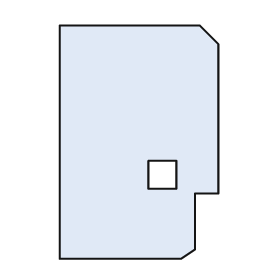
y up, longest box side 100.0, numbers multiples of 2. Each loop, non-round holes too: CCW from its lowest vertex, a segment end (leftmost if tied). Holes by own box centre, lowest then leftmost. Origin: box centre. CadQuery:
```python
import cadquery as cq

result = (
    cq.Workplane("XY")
    .moveTo(-34.0, -50.0)
    .lineTo(18.0, -50.0)
    .lineTo(24.0, -46.0)
    .lineTo(24.0, -22.0)
    .lineTo(34.0, -22.0)
    .lineTo(34.0, 42.0)
    .lineTo(26.0, 50.0)
    .lineTo(-34.0, 50.0)
    .close()
    .moveTo(4.0, -20.0)
    .lineTo(16.0, -20.0)
    .lineTo(16.0, -8.0)
    .lineTo(4.0, -8.0)
    .close()
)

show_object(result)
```